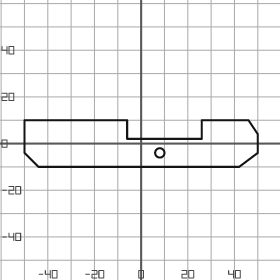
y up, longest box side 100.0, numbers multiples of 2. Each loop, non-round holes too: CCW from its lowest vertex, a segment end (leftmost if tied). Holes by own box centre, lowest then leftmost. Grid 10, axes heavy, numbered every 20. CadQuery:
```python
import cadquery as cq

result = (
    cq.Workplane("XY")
    .moveTo(-44.0, -10.0)
    .lineTo(42.0, -10.0)
    .lineTo(50.0, -4.0)
    .lineTo(50.0, 4.0)
    .lineTo(46.0, 10.0)
    .lineTo(26.0, 10.0)
    .lineTo(26.0, 2.0)
    .lineTo(-6.0, 2.0)
    .lineTo(-6.0, 10.0)
    .lineTo(-50.0, 10.0)
    .lineTo(-50.0, -4.0)
    .close()
    .moveTo(8.0, -4.0)
    .circle(2.0)
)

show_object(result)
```